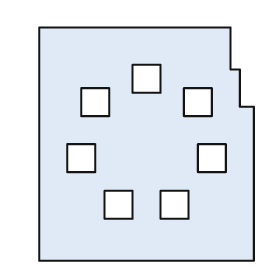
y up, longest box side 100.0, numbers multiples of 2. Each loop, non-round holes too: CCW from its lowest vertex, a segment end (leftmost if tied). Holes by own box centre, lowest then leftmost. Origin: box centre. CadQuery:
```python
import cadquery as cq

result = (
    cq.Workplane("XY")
    .moveTo(-46.0, -50.0)
    .lineTo(46.0, -50.0)
    .lineTo(46.0, 16.0)
    .lineTo(40.0, 16.0)
    .lineTo(40.0, 32.0)
    .lineTo(36.0, 32.0)
    .lineTo(36.0, 50.0)
    .lineTo(-46.0, 50.0)
    .close()
    .moveTo(-18.0, -32.0)
    .lineTo(-6.0, -32.0)
    .lineTo(-6.0, -20.0)
    .lineTo(-18.0, -20.0)
    .close()
    .moveTo(6.0, -32.0)
    .lineTo(18.0, -32.0)
    .lineTo(18.0, -20.0)
    .lineTo(6.0, -20.0)
    .close()
    .moveTo(-34.0, -12.0)
    .lineTo(-22.0, -12.0)
    .lineTo(-22.0, 0.0)
    .lineTo(-34.0, 0.0)
    .close()
    .moveTo(22.0, -12.0)
    .lineTo(34.0, -12.0)
    .lineTo(34.0, 0.0)
    .lineTo(22.0, 0.0)
    .close()
    .moveTo(-28.0, 12.0)
    .lineTo(-16.0, 12.0)
    .lineTo(-16.0, 24.0)
    .lineTo(-28.0, 24.0)
    .close()
    .moveTo(16.0, 12.0)
    .lineTo(28.0, 12.0)
    .lineTo(28.0, 24.0)
    .lineTo(16.0, 24.0)
    .close()
    .moveTo(-6.0, 22.0)
    .lineTo(6.0, 22.0)
    .lineTo(6.0, 34.0)
    .lineTo(-6.0, 34.0)
    .close()
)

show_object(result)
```